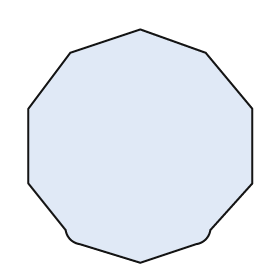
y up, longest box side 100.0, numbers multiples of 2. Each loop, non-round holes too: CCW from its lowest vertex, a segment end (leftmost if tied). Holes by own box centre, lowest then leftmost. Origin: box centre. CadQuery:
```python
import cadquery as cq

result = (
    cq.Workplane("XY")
    .moveTo(0.0, -50.0)
    .lineTo(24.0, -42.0)
    .threePointArc((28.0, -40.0), (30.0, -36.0))
    .lineTo(48.0, -16.0)
    .lineTo(48.0, 16.0)
    .lineTo(28.0, 40.0)
    .lineTo(0.0, 50.0)
    .lineTo(-30.0, 40.0)
    .lineTo(-48.0, 16.0)
    .lineTo(-48.0, -16.0)
    .lineTo(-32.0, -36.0)
    .threePointArc((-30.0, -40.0), (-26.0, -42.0))
    .close()
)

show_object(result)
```